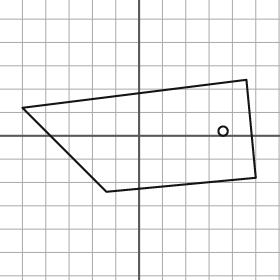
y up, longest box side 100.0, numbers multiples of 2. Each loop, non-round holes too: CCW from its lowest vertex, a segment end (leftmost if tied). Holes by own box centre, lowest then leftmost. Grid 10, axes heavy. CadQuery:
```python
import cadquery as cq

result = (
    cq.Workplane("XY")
    .moveTo(-14.0, -24.0)
    .lineTo(50.0, -18.0)
    .lineTo(46.0, 24.0)
    .lineTo(-50.0, 12.0)
    .close()
    .moveTo(36.0, 2.0)
    .circle(2.0)
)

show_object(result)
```